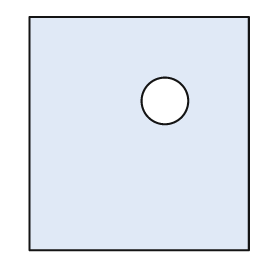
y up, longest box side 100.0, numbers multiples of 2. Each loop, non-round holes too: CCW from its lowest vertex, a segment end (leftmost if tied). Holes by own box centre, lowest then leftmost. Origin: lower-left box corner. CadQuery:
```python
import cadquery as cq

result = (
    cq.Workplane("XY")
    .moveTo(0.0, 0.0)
    .lineTo(94.0, 0.0)
    .lineTo(94.0, 100.0)
    .lineTo(0.0, 100.0)
    .close()
    .moveTo(58.0, 64.0)
    .circle(10.0)
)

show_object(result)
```